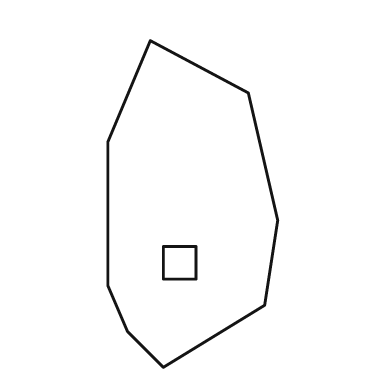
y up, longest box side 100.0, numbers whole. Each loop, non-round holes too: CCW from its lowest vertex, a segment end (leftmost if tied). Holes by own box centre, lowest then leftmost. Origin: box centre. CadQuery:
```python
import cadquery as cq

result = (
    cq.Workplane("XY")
    .moveTo(-9.0, -50.0)
    .lineTo(22.0, -31.0)
    .lineTo(26.0, -5.0)
    .lineTo(17.0, 34.0)
    .lineTo(-13.0, 50.0)
    .lineTo(-26.0, 19.0)
    .lineTo(-26.0, -25.0)
    .lineTo(-20.0, -39.0)
    .close()
    .moveTo(-9.0, -23.0)
    .lineTo(1.0, -23.0)
    .lineTo(1.0, -13.0)
    .lineTo(-9.0, -13.0)
    .close()
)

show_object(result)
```